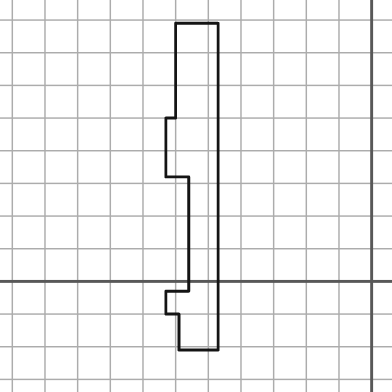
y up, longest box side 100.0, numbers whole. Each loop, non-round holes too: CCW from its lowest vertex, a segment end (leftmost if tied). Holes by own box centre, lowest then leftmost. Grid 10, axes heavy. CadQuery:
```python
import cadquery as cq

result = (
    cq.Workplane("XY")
    .moveTo(-59.0, -21.0)
    .lineTo(-47.0, -21.0)
    .lineTo(-47.0, 79.0)
    .lineTo(-60.0, 79.0)
    .lineTo(-60.0, 50.0)
    .lineTo(-63.0, 50.0)
    .lineTo(-63.0, 32.0)
    .lineTo(-56.0, 32.0)
    .lineTo(-56.0, -3.0)
    .lineTo(-63.0, -3.0)
    .lineTo(-63.0, -10.0)
    .lineTo(-59.0, -10.0)
    .close()
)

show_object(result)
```